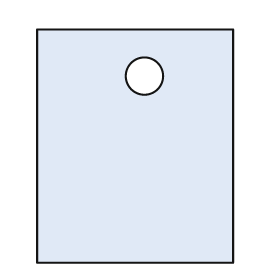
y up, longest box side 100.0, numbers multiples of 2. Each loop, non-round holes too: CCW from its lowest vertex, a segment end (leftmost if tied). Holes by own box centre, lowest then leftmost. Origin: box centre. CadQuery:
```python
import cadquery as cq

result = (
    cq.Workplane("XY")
    .moveTo(-42.0, -50.0)
    .lineTo(42.0, -50.0)
    .lineTo(42.0, 50.0)
    .lineTo(-42.0, 50.0)
    .close()
    .moveTo(4.0, 30.0)
    .circle(8.0)
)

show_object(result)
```